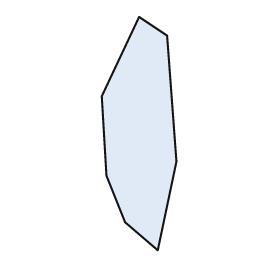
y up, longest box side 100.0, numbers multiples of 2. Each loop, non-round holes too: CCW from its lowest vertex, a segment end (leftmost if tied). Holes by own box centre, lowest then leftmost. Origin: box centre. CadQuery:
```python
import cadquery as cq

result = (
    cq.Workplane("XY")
    .moveTo(8.0, -50.0)
    .lineTo(16.0, -12.0)
    .lineTo(12.0, 42.0)
    .lineTo(0.0, 50.0)
    .lineTo(-16.0, 16.0)
    .lineTo(-14.0, -18.0)
    .lineTo(-6.0, -38.0)
    .close()
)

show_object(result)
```